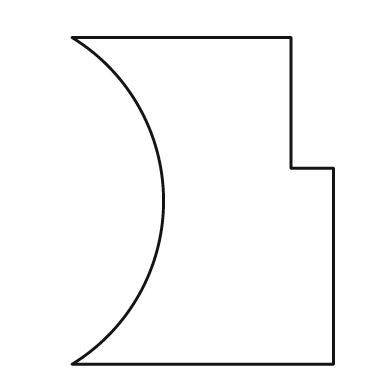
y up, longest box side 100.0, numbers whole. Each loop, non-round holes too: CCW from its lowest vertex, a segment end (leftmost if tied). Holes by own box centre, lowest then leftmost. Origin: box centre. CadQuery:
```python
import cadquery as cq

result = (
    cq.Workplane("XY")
    .moveTo(-40.0, -50.0)
    .lineTo(40.0, -50.0)
    .lineTo(40.0, 10.0)
    .lineTo(27.0, 10.0)
    .lineTo(27.0, 50.0)
    .lineTo(-40.0, 50.0)
    .threePointArc((-12.0, 0.0), (-40.0, -50.0))
    .close()
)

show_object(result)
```